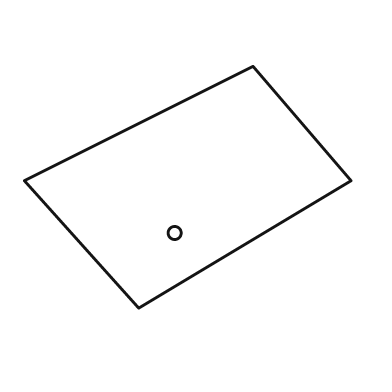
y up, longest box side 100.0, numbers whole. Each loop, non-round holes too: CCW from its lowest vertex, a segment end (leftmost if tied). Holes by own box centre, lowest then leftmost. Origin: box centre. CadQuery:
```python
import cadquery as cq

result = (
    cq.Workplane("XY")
    .moveTo(-15.0, -37.0)
    .lineTo(50.0, 2.0)
    .lineTo(20.0, 37.0)
    .lineTo(-50.0, 2.0)
    .close()
    .moveTo(-4.0, -14.0)
    .circle(2.0)
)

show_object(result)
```